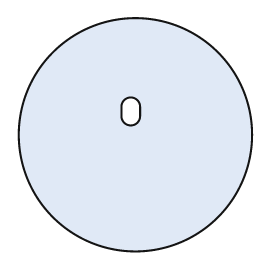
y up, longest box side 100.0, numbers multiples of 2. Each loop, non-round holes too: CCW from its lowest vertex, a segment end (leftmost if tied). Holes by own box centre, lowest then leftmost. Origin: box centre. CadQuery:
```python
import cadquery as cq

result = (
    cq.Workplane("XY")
    .moveTo(0.0, 0.0)
    .circle(50.0)
    .moveTo(-6.0, 8.0)
    .threePointArc((-2.0, 4.0), (2.0, 8.0))
    .lineTo(2.0, 12.0)
    .threePointArc((-2.0, 16.0), (-6.0, 12.0))
    .close()
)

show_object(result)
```